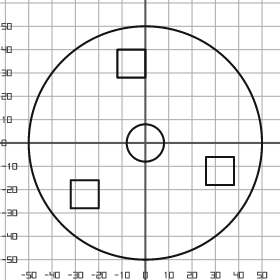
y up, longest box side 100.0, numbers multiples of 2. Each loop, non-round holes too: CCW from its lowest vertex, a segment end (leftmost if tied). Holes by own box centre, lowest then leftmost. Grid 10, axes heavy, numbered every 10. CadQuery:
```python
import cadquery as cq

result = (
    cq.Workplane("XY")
    .moveTo(0.0, 0.0)
    .circle(50.0)
    .moveTo(-32.0, -28.0)
    .lineTo(-20.0, -28.0)
    .lineTo(-20.0, -16.0)
    .lineTo(-32.0, -16.0)
    .close()
    .moveTo(26.0, -18.0)
    .lineTo(38.0, -18.0)
    .lineTo(38.0, -6.0)
    .lineTo(26.0, -6.0)
    .close()
    .moveTo(0.0, 0.0)
    .circle(8.0)
    .moveTo(-12.0, 28.0)
    .lineTo(0.0, 28.0)
    .lineTo(0.0, 40.0)
    .lineTo(-12.0, 40.0)
    .close()
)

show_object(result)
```